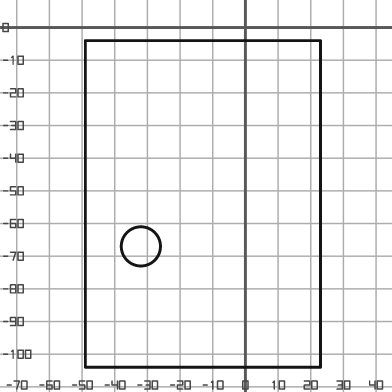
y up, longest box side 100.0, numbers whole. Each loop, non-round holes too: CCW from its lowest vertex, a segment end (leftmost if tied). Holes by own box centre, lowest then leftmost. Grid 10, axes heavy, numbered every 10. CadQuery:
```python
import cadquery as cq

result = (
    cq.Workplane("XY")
    .moveTo(-49.0, -104.0)
    .lineTo(23.0, -104.0)
    .lineTo(23.0, -4.0)
    .lineTo(-49.0, -4.0)
    .close()
    .moveTo(-32.0, -67.0)
    .circle(6.0)
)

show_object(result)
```